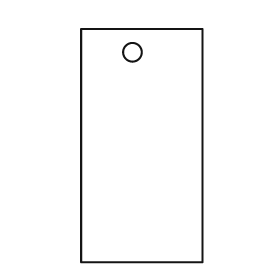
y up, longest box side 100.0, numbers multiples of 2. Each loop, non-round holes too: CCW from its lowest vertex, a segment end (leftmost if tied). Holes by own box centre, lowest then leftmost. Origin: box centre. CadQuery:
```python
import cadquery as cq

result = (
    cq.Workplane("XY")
    .moveTo(-26.0, -50.0)
    .lineTo(26.0, -50.0)
    .lineTo(26.0, 50.0)
    .lineTo(-26.0, 50.0)
    .close()
    .moveTo(-4.0, 40.0)
    .circle(4.0)
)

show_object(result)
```